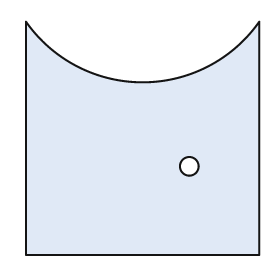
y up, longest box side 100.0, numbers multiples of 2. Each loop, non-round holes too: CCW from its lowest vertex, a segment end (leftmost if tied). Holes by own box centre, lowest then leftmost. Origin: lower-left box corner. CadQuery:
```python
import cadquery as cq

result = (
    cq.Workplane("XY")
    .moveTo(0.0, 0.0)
    .lineTo(100.0, 0.0)
    .lineTo(100.0, 100.0)
    .threePointArc((50.0, 74.0), (0.0, 100.0))
    .close()
    .moveTo(70.0, 38.0)
    .circle(4.0)
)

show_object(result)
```